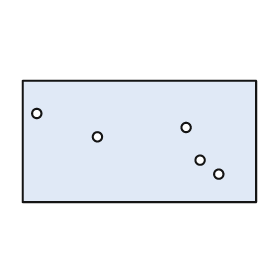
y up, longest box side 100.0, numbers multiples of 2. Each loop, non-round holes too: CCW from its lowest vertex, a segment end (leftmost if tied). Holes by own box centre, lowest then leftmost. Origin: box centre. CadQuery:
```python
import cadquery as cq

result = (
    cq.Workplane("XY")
    .moveTo(-50.0, -26.0)
    .lineTo(50.0, -26.0)
    .lineTo(50.0, 26.0)
    .lineTo(-50.0, 26.0)
    .close()
    .moveTo(34.0, -14.0)
    .circle(2.0)
    .moveTo(26.0, -8.0)
    .circle(2.0)
    .moveTo(-18.0, 2.0)
    .circle(2.0)
    .moveTo(20.0, 6.0)
    .circle(2.0)
    .moveTo(-44.0, 12.0)
    .circle(2.0)
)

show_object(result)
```